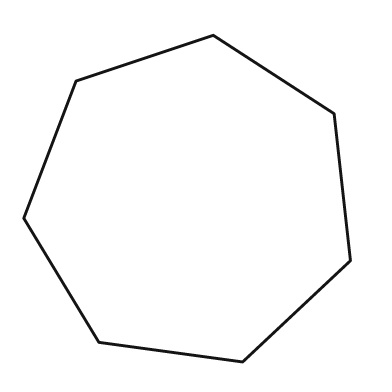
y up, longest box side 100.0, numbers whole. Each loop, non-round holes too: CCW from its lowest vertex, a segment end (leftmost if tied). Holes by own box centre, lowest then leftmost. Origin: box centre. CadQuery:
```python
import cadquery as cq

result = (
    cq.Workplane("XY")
    .moveTo(17.0, -50.0)
    .lineTo(50.0, -19.0)
    .lineTo(45.0, 26.0)
    .lineTo(8.0, 50.0)
    .lineTo(-34.0, 36.0)
    .lineTo(-50.0, -6.0)
    .lineTo(-27.0, -44.0)
    .close()
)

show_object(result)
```